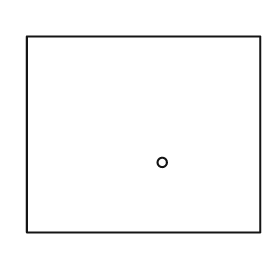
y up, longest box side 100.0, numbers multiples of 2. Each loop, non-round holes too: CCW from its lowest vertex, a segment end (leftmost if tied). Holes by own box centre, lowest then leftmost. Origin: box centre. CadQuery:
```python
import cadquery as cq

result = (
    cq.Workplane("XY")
    .moveTo(-50.0, -42.0)
    .lineTo(50.0, -42.0)
    .lineTo(50.0, 42.0)
    .lineTo(-50.0, 42.0)
    .close()
    .moveTo(8.0, -12.0)
    .circle(2.0)
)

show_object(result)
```